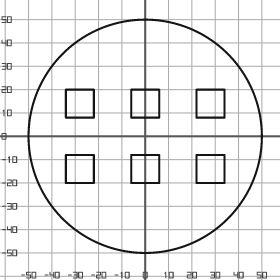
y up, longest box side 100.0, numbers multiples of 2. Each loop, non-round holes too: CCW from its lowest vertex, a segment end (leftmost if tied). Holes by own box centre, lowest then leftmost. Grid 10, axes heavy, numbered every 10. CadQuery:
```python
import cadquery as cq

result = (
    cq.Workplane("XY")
    .moveTo(0.0, 0.0)
    .circle(50.0)
    .moveTo(-34.0, -20.0)
    .lineTo(-22.0, -20.0)
    .lineTo(-22.0, -8.0)
    .lineTo(-34.0, -8.0)
    .close()
    .moveTo(-6.0, -20.0)
    .lineTo(6.0, -20.0)
    .lineTo(6.0, -8.0)
    .lineTo(-6.0, -8.0)
    .close()
    .moveTo(22.0, -20.0)
    .lineTo(34.0, -20.0)
    .lineTo(34.0, -8.0)
    .lineTo(22.0, -8.0)
    .close()
    .moveTo(-34.0, 8.0)
    .lineTo(-22.0, 8.0)
    .lineTo(-22.0, 20.0)
    .lineTo(-34.0, 20.0)
    .close()
    .moveTo(-6.0, 8.0)
    .lineTo(6.0, 8.0)
    .lineTo(6.0, 20.0)
    .lineTo(-6.0, 20.0)
    .close()
    .moveTo(22.0, 8.0)
    .lineTo(34.0, 8.0)
    .lineTo(34.0, 20.0)
    .lineTo(22.0, 20.0)
    .close()
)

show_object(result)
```